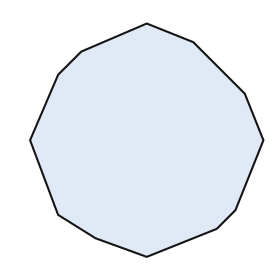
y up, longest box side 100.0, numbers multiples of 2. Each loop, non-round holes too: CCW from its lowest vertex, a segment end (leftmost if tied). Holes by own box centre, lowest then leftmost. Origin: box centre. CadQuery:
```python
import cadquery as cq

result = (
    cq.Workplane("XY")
    .moveTo(0.0, -50.0)
    .lineTo(30.0, -38.0)
    .lineTo(38.0, -30.0)
    .lineTo(50.0, 0.0)
    .lineTo(42.0, 20.0)
    .lineTo(20.0, 42.0)
    .lineTo(0.0, 50.0)
    .lineTo(-28.0, 38.0)
    .lineTo(-38.0, 28.0)
    .lineTo(-50.0, 0.0)
    .lineTo(-38.0, -32.0)
    .lineTo(-22.0, -42.0)
    .close()
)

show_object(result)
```